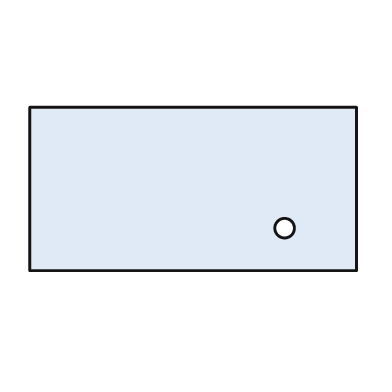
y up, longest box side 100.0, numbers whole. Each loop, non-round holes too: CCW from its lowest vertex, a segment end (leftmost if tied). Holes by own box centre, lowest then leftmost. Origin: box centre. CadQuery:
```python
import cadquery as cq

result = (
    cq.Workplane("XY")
    .moveTo(-50.0, -25.0)
    .lineTo(50.0, -25.0)
    .lineTo(50.0, 25.0)
    .lineTo(-50.0, 25.0)
    .close()
    .moveTo(28.0, -12.0)
    .circle(3.0)
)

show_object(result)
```